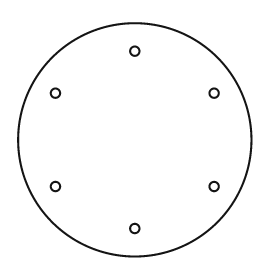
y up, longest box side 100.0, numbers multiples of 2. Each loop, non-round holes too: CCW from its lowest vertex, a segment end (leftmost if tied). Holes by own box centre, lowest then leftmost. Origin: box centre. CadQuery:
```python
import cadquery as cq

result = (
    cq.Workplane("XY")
    .moveTo(0.0, 0.0)
    .circle(50.0)
    .moveTo(0.0, -38.0)
    .circle(2.0)
    .moveTo(-34.0, -20.0)
    .circle(2.0)
    .moveTo(34.0, -20.0)
    .circle(2.0)
    .moveTo(-34.0, 20.0)
    .circle(2.0)
    .moveTo(34.0, 20.0)
    .circle(2.0)
    .moveTo(0.0, 38.0)
    .circle(2.0)
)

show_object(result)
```